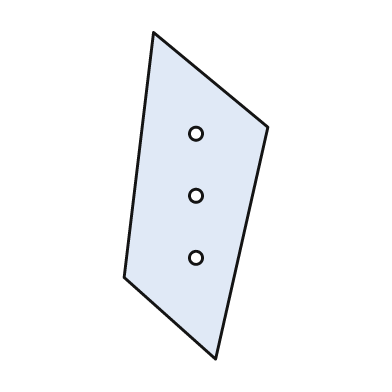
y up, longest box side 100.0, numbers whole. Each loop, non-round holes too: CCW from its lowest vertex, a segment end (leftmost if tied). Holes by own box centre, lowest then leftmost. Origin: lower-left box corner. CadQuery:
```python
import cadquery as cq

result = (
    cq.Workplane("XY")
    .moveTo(28.0, 0.0)
    .lineTo(44.0, 71.0)
    .lineTo(9.0, 100.0)
    .lineTo(0.0, 25.0)
    .close()
    .moveTo(22.0, 31.0)
    .circle(2.0)
    .moveTo(22.0, 50.0)
    .circle(2.0)
    .moveTo(22.0, 69.0)
    .circle(2.0)
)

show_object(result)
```